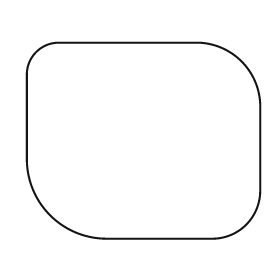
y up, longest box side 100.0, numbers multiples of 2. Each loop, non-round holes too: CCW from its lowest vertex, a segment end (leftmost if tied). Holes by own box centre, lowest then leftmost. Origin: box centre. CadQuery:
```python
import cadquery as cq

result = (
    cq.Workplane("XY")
    .moveTo(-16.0, -42.0)
    .lineTo(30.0, -42.0)
    .threePointArc((44.0, -36.0), (50.0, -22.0))
    .lineTo(50.0, 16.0)
    .threePointArc((42.0, 34.0), (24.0, 42.0))
    .lineTo(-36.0, 42.0)
    .threePointArc((-46.0, 38.0), (-50.0, 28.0))
    .lineTo(-50.0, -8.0)
    .threePointArc((-40.0, -32.0), (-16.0, -42.0))
    .close()
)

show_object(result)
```